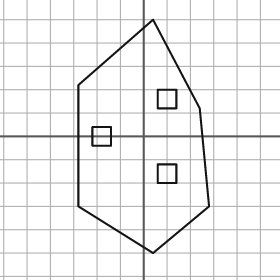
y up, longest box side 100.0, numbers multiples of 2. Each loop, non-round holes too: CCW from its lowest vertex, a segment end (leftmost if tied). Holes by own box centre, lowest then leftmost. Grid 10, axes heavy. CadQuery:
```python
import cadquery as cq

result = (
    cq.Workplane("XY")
    .moveTo(4.0, -50.0)
    .lineTo(28.0, -30.0)
    .lineTo(24.0, 12.0)
    .lineTo(4.0, 50.0)
    .lineTo(-28.0, 22.0)
    .lineTo(-28.0, -30.0)
    .close()
    .moveTo(6.0, -20.0)
    .lineTo(14.0, -20.0)
    .lineTo(14.0, -12.0)
    .lineTo(6.0, -12.0)
    .close()
    .moveTo(-22.0, -4.0)
    .lineTo(-14.0, -4.0)
    .lineTo(-14.0, 4.0)
    .lineTo(-22.0, 4.0)
    .close()
    .moveTo(6.0, 12.0)
    .lineTo(14.0, 12.0)
    .lineTo(14.0, 20.0)
    .lineTo(6.0, 20.0)
    .close()
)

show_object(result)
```